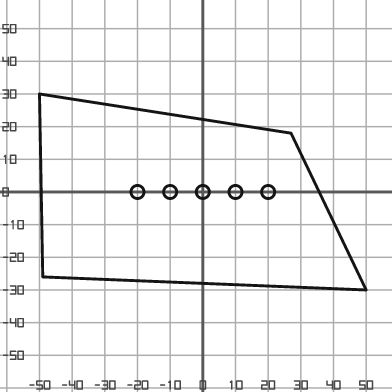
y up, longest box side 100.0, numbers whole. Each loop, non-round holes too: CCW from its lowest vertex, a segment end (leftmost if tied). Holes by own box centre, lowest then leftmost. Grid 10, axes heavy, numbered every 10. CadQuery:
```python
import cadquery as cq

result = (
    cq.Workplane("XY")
    .moveTo(50.0, -30.0)
    .lineTo(27.0, 18.0)
    .lineTo(-50.0, 30.0)
    .lineTo(-49.0, -26.0)
    .close()
    .moveTo(-20.0, 0.0)
    .circle(2.0)
    .moveTo(-10.0, 0.0)
    .circle(2.0)
    .moveTo(0.0, 0.0)
    .circle(2.0)
    .moveTo(10.0, 0.0)
    .circle(2.0)
    .moveTo(20.0, 0.0)
    .circle(2.0)
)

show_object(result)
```